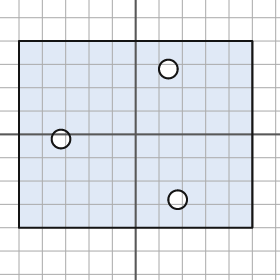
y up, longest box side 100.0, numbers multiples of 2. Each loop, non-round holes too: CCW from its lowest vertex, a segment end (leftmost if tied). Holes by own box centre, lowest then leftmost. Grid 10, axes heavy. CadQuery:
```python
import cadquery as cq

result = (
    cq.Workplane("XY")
    .moveTo(-50.0, -40.0)
    .lineTo(50.0, -40.0)
    .lineTo(50.0, 40.0)
    .lineTo(-50.0, 40.0)
    .close()
    .moveTo(18.0, -28.0)
    .circle(4.0)
    .moveTo(-32.0, -2.0)
    .circle(4.0)
    .moveTo(14.0, 28.0)
    .circle(4.0)
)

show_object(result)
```